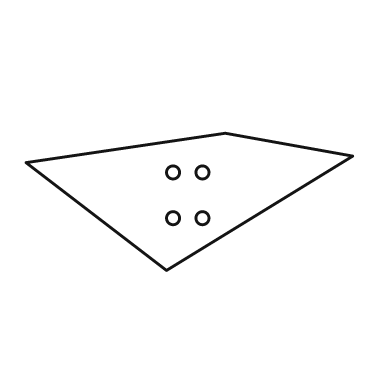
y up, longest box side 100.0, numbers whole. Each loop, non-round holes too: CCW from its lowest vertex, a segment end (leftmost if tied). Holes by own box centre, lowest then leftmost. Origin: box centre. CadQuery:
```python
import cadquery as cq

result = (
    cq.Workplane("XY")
    .moveTo(-7.0, -21.0)
    .lineTo(50.0, 14.0)
    .lineTo(11.0, 21.0)
    .lineTo(-50.0, 12.0)
    .close()
    .moveTo(-5.0, -5.0)
    .circle(2.0)
    .moveTo(4.0, -5.0)
    .circle(2.0)
    .moveTo(-5.0, 9.0)
    .circle(2.0)
    .moveTo(4.0, 9.0)
    .circle(2.0)
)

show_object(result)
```